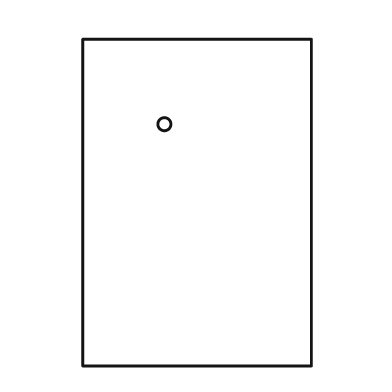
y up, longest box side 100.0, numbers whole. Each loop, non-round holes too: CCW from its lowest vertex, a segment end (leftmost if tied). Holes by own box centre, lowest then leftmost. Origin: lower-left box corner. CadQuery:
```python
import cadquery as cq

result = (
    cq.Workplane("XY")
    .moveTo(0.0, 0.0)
    .lineTo(70.0, 0.0)
    .lineTo(70.0, 100.0)
    .lineTo(0.0, 100.0)
    .close()
    .moveTo(25.0, 74.0)
    .circle(2.0)
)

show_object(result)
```